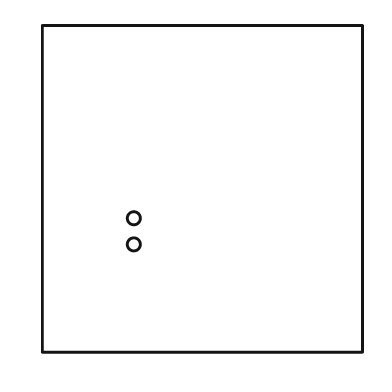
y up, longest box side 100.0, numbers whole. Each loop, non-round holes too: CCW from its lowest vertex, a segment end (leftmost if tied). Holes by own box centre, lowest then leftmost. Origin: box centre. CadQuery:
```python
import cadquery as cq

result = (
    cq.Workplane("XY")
    .moveTo(-49.0, -50.0)
    .lineTo(49.0, -50.0)
    .lineTo(49.0, 50.0)
    .lineTo(-49.0, 50.0)
    .close()
    .moveTo(-21.0, -17.0)
    .circle(2.0)
    .moveTo(-21.0, -9.0)
    .circle(2.0)
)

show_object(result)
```